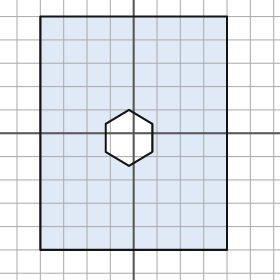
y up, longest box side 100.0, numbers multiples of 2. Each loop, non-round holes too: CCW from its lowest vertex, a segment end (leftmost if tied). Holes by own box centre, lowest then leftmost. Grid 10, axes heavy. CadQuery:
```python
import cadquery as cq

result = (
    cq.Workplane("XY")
    .moveTo(-40.0, -50.0)
    .lineTo(40.0, -50.0)
    .lineTo(40.0, 50.0)
    .lineTo(-40.0, 50.0)
    .close()
    .moveTo(-2.0, -14.0)
    .lineTo(8.0, -8.0)
    .lineTo(8.0, 4.0)
    .lineTo(-2.0, 10.0)
    .lineTo(-12.0, 4.0)
    .lineTo(-12.0, -8.0)
    .close()
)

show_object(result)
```